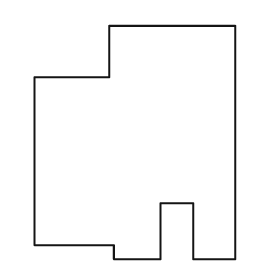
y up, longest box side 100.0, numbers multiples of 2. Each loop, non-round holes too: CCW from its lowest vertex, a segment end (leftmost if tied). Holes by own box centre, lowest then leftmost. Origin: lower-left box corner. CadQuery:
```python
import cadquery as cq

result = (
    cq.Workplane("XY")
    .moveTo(34.0, 0.0)
    .lineTo(54.0, 0.0)
    .lineTo(54.0, 24.0)
    .lineTo(68.0, 24.0)
    .lineTo(68.0, 0.0)
    .lineTo(86.0, 0.0)
    .lineTo(86.0, 100.0)
    .lineTo(32.0, 100.0)
    .lineTo(32.0, 78.0)
    .lineTo(0.0, 78.0)
    .lineTo(0.0, 6.0)
    .lineTo(34.0, 6.0)
    .close()
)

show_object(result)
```